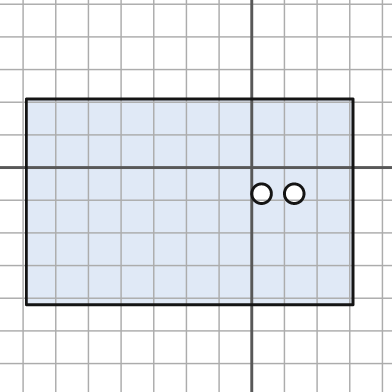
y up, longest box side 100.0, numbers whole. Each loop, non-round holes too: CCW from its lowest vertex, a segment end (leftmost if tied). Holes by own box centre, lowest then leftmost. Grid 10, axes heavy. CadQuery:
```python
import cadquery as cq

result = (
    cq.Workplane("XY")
    .moveTo(-69.0, -42.0)
    .lineTo(31.0, -42.0)
    .lineTo(31.0, 21.0)
    .lineTo(-69.0, 21.0)
    .close()
    .moveTo(3.0, -8.0)
    .circle(3.0)
    .moveTo(13.0, -8.0)
    .circle(3.0)
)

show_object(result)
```